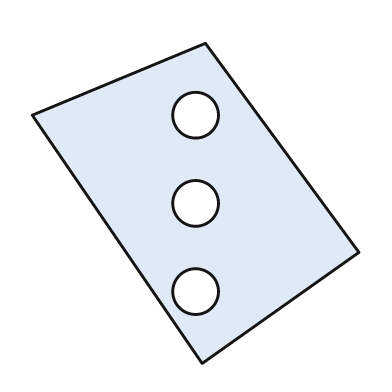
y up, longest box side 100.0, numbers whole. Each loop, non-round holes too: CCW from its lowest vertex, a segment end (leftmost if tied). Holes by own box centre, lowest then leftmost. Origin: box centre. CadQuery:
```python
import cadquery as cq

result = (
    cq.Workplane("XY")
    .moveTo(2.0, -49.0)
    .lineTo(50.0, -15.0)
    .lineTo(3.0, 49.0)
    .lineTo(-50.0, 27.0)
    .close()
    .moveTo(0.0, -27.0)
    .circle(7.0)
    .moveTo(0.0, 0.0)
    .circle(7.0)
    .moveTo(0.0, 27.0)
    .circle(7.0)
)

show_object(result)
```